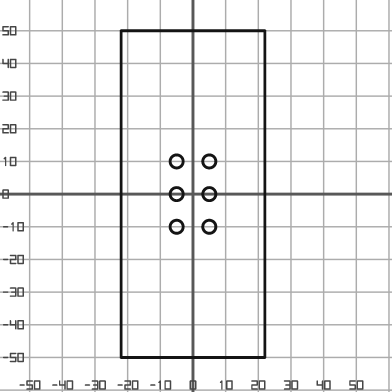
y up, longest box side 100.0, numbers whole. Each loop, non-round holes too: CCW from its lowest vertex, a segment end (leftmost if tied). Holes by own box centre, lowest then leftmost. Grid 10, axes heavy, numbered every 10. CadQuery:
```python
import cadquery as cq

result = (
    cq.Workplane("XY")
    .moveTo(-22.0, -50.0)
    .lineTo(22.0, -50.0)
    .lineTo(22.0, 50.0)
    .lineTo(-22.0, 50.0)
    .close()
    .moveTo(-5.0, -10.0)
    .circle(2.0)
    .moveTo(5.0, -10.0)
    .circle(2.0)
    .moveTo(-5.0, 0.0)
    .circle(2.0)
    .moveTo(5.0, 0.0)
    .circle(2.0)
    .moveTo(-5.0, 10.0)
    .circle(2.0)
    .moveTo(5.0, 10.0)
    .circle(2.0)
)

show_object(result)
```